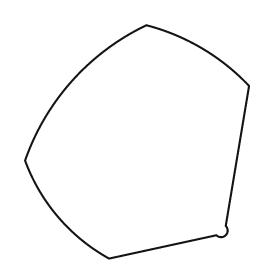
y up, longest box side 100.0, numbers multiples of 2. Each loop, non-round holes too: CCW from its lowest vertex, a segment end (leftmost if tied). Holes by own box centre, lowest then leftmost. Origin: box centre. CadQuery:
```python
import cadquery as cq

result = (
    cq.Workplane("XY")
    .moveTo(-12.0, -50.0)
    .lineTo(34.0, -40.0)
    .threePointArc((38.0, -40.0), (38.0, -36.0))
    .lineTo(48.0, 24.0)
    .threePointArc((28.0, 40.0), (4.0, 50.0))
    .threePointArc((-28.0, 26.0), (-48.0, -8.0))
    .threePointArc((-34.0, -32.0), (-12.0, -50.0))
    .close()
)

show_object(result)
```